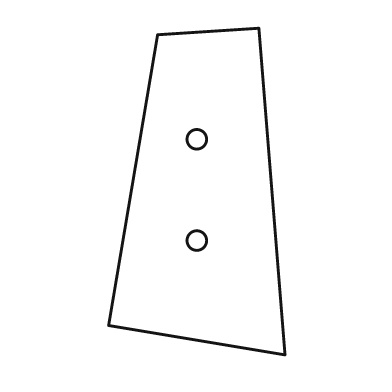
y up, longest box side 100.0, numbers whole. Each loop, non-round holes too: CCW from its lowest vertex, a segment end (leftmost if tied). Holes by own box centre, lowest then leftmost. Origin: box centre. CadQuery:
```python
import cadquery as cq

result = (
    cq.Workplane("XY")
    .moveTo(27.0, -50.0)
    .lineTo(19.0, 50.0)
    .lineTo(-12.0, 48.0)
    .lineTo(-27.0, -41.0)
    .close()
    .moveTo(0.0, -15.0)
    .circle(3.0)
    .moveTo(0.0, 16.0)
    .circle(3.0)
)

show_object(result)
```